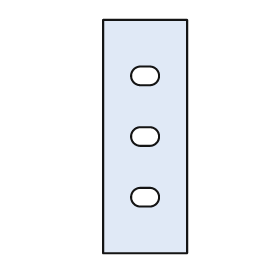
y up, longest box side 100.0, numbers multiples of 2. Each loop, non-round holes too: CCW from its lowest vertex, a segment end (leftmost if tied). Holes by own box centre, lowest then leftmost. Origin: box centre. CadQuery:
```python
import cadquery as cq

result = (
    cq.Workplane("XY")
    .moveTo(-18.0, -50.0)
    .lineTo(18.0, -50.0)
    .lineTo(18.0, 50.0)
    .lineTo(-18.0, 50.0)
    .close()
    .moveTo(-2.0, -30.0)
    .lineTo(2.0, -30.0)
    .threePointArc((6.0, -26.0), (2.0, -22.0))
    .lineTo(-2.0, -22.0)
    .threePointArc((-6.0, -26.0), (-2.0, -30.0))
    .close()
    .moveTo(-2.0, -4.0)
    .lineTo(2.0, -4.0)
    .threePointArc((6.0, 0.0), (2.0, 4.0))
    .lineTo(-2.0, 4.0)
    .threePointArc((-6.0, 0.0), (-2.0, -4.0))
    .close()
    .moveTo(-2.0, 22.0)
    .lineTo(2.0, 22.0)
    .threePointArc((6.0, 26.0), (2.0, 30.0))
    .lineTo(-2.0, 30.0)
    .threePointArc((-6.0, 26.0), (-2.0, 22.0))
    .close()
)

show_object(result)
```